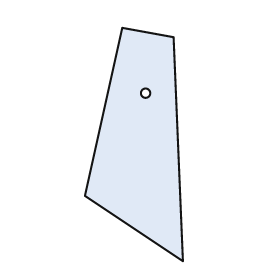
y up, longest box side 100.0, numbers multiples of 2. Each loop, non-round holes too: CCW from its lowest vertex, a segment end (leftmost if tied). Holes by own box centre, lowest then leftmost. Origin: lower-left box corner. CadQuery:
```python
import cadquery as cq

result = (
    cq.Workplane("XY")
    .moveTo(42.0, 0.0)
    .lineTo(38.0, 96.0)
    .lineTo(16.0, 100.0)
    .lineTo(0.0, 28.0)
    .close()
    .moveTo(26.0, 72.0)
    .circle(2.0)
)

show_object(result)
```